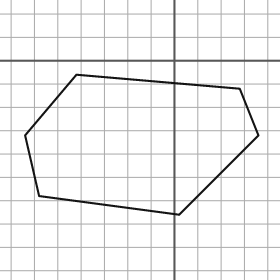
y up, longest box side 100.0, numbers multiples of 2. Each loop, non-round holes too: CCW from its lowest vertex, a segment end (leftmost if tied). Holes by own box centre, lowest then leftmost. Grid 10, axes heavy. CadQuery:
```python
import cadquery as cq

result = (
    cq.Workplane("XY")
    .moveTo(2.0, -66.0)
    .lineTo(36.0, -32.0)
    .lineTo(28.0, -12.0)
    .lineTo(-42.0, -6.0)
    .lineTo(-64.0, -32.0)
    .lineTo(-58.0, -58.0)
    .close()
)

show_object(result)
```